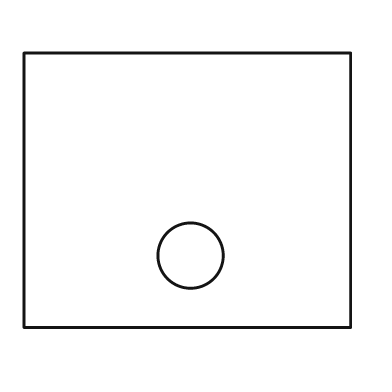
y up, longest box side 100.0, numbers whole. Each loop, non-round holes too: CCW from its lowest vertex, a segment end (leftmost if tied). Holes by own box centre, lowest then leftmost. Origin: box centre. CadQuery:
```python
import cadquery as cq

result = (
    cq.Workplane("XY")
    .moveTo(-50.0, -42.0)
    .lineTo(50.0, -42.0)
    .lineTo(50.0, 42.0)
    .lineTo(-50.0, 42.0)
    .close()
    .moveTo(1.0, -20.0)
    .circle(10.0)
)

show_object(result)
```